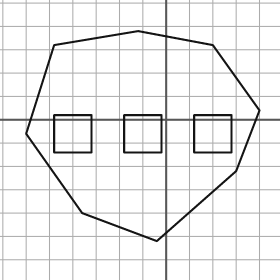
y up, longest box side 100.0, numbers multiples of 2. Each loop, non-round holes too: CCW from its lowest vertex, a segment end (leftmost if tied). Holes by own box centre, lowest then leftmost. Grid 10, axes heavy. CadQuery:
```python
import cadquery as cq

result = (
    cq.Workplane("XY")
    .moveTo(-4.0, -52.0)
    .lineTo(30.0, -22.0)
    .lineTo(40.0, 4.0)
    .lineTo(20.0, 32.0)
    .lineTo(-12.0, 38.0)
    .lineTo(-48.0, 32.0)
    .lineTo(-60.0, -6.0)
    .lineTo(-36.0, -40.0)
    .close()
    .moveTo(-48.0, -14.0)
    .lineTo(-32.0, -14.0)
    .lineTo(-32.0, 2.0)
    .lineTo(-48.0, 2.0)
    .close()
    .moveTo(-18.0, -14.0)
    .lineTo(-2.0, -14.0)
    .lineTo(-2.0, 2.0)
    .lineTo(-18.0, 2.0)
    .close()
    .moveTo(12.0, -14.0)
    .lineTo(28.0, -14.0)
    .lineTo(28.0, 2.0)
    .lineTo(12.0, 2.0)
    .close()
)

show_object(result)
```